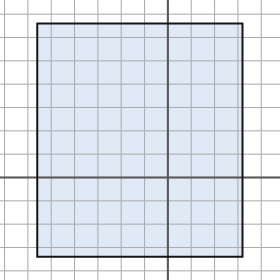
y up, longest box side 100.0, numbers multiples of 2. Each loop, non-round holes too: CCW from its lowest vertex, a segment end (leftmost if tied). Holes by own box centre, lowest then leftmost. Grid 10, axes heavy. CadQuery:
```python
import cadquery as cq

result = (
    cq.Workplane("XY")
    .moveTo(-56.0, -34.0)
    .lineTo(32.0, -34.0)
    .lineTo(32.0, 66.0)
    .lineTo(-56.0, 66.0)
    .close()
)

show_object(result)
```